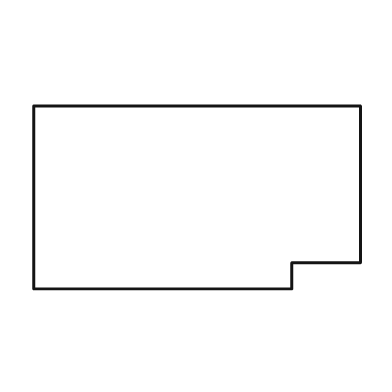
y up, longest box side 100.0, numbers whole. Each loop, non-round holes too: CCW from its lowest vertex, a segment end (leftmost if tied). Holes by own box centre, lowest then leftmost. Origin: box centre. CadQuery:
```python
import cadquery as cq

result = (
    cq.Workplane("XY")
    .moveTo(-50.0, -28.0)
    .lineTo(29.0, -28.0)
    .lineTo(29.0, -20.0)
    .lineTo(50.0, -20.0)
    .lineTo(50.0, 28.0)
    .lineTo(-50.0, 28.0)
    .close()
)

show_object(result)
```